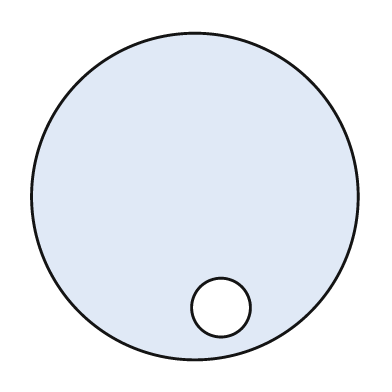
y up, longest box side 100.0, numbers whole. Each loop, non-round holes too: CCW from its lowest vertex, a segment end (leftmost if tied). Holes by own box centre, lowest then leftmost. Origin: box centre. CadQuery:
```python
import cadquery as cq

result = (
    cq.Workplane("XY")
    .moveTo(0.0, 0.0)
    .circle(50.0)
    .moveTo(8.0, -34.0)
    .circle(9.0)
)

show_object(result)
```